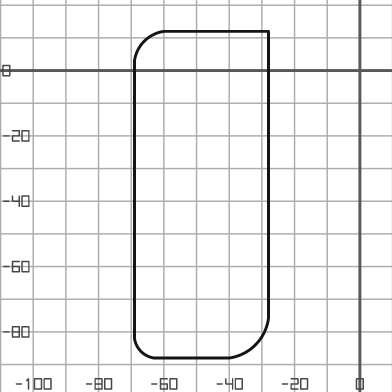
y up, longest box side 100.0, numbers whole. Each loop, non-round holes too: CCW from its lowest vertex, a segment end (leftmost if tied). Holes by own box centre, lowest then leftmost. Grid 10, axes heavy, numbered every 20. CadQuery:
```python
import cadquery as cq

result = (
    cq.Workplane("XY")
    .moveTo(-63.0, -88.0)
    .lineTo(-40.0, -88.0)
    .threePointArc((-32.0, -84.0), (-28.0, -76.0))
    .lineTo(-28.0, 12.0)
    .lineTo(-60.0, 12.0)
    .threePointArc((-66.0, 9.0), (-69.0, 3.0))
    .lineTo(-69.0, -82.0)
    .threePointArc((-67.0, -86.0), (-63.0, -88.0))
    .close()
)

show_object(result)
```